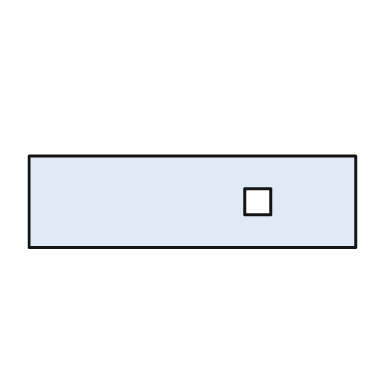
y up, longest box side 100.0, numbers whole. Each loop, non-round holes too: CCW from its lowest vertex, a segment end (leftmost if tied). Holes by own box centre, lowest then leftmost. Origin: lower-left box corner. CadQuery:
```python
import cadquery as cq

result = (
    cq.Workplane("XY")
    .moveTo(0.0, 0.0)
    .lineTo(100.0, 0.0)
    .lineTo(100.0, 28.0)
    .lineTo(0.0, 28.0)
    .close()
    .moveTo(66.0, 10.0)
    .lineTo(74.0, 10.0)
    .lineTo(74.0, 18.0)
    .lineTo(66.0, 18.0)
    .close()
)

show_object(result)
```